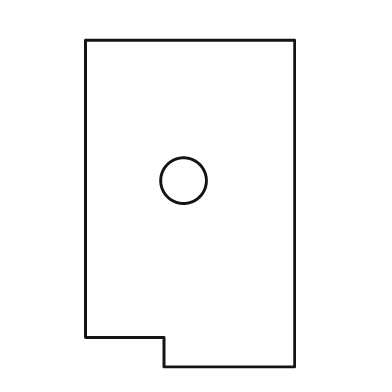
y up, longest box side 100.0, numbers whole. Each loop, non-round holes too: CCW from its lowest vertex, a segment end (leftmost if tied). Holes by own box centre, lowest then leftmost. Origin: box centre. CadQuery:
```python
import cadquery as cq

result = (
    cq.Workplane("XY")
    .moveTo(-8.0, -50.0)
    .lineTo(32.0, -50.0)
    .lineTo(32.0, 50.0)
    .lineTo(-32.0, 50.0)
    .lineTo(-32.0, -41.0)
    .lineTo(-8.0, -41.0)
    .close()
    .moveTo(-2.0, 7.0)
    .circle(7.0)
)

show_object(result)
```